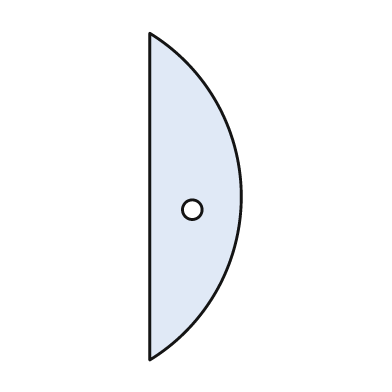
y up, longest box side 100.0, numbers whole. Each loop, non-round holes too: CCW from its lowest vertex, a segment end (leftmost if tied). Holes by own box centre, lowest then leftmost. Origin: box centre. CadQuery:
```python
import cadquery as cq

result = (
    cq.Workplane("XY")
    .moveTo(-14.0, -50.0)
    .threePointArc((14.0, 0.0), (-14.0, 50.0))
    .close()
    .moveTo(-1.0, -4.0)
    .circle(3.0)
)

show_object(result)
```